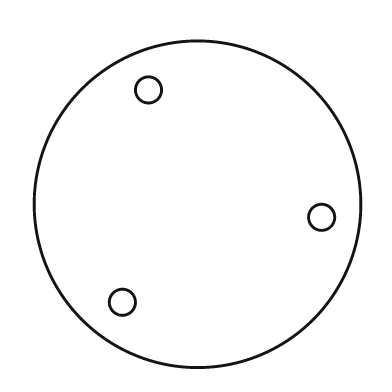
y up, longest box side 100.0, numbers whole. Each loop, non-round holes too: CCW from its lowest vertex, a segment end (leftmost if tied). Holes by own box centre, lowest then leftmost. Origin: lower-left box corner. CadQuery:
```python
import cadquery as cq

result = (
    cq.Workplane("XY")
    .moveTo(50.0, 50.0)
    .circle(50.0)
    .moveTo(27.0, 20.0)
    .circle(4.0)
    .moveTo(88.0, 46.0)
    .circle(4.0)
    .moveTo(35.0, 85.0)
    .circle(4.0)
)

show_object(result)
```